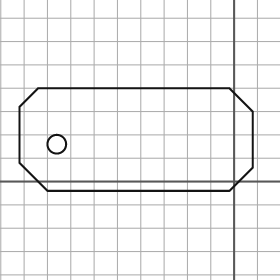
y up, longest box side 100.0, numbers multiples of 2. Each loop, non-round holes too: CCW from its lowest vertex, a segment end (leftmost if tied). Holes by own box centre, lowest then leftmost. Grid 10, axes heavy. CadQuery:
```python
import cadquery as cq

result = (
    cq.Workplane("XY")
    .moveTo(-80.0, -4.0)
    .lineTo(-2.0, -4.0)
    .lineTo(8.0, 6.0)
    .lineTo(8.0, 30.0)
    .lineTo(-2.0, 40.0)
    .lineTo(-84.0, 40.0)
    .lineTo(-92.0, 32.0)
    .lineTo(-92.0, 8.0)
    .close()
    .moveTo(-76.0, 16.0)
    .circle(4.0)
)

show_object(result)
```